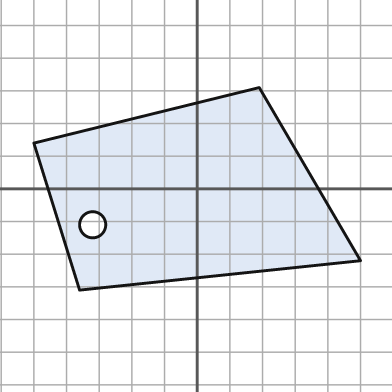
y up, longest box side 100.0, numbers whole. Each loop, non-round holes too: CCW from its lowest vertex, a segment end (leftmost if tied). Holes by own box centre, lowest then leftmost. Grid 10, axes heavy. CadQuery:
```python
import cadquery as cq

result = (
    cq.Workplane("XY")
    .moveTo(-36.0, -31.0)
    .lineTo(50.0, -22.0)
    .lineTo(19.0, 31.0)
    .lineTo(-50.0, 14.0)
    .close()
    .moveTo(-32.0, -11.0)
    .circle(4.0)
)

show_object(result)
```